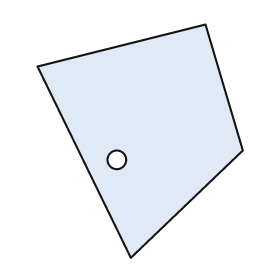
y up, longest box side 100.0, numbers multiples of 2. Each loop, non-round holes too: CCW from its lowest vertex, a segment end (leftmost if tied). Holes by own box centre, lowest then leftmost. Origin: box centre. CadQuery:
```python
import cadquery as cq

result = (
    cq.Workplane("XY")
    .moveTo(-4.0, -50.0)
    .lineTo(44.0, -4.0)
    .lineTo(28.0, 50.0)
    .lineTo(-44.0, 32.0)
    .close()
    .moveTo(-10.0, -8.0)
    .circle(4.0)
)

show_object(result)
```